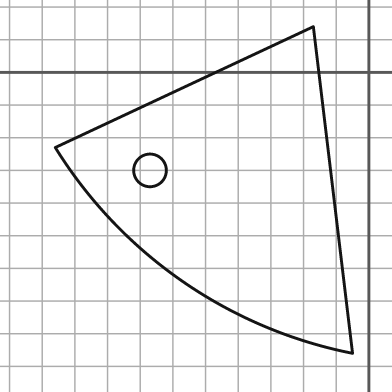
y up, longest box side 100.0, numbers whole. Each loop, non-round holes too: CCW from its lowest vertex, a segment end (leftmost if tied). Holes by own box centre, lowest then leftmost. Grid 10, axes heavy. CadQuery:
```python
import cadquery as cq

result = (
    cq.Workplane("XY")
    .moveTo(-5.0, -86.0)
    .lineTo(-17.0, 14.0)
    .lineTo(-96.0, -23.0)
    .threePointArc((-57.0, -64.0), (-5.0, -86.0))
    .close()
    .moveTo(-67.0, -30.0)
    .circle(5.0)
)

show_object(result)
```